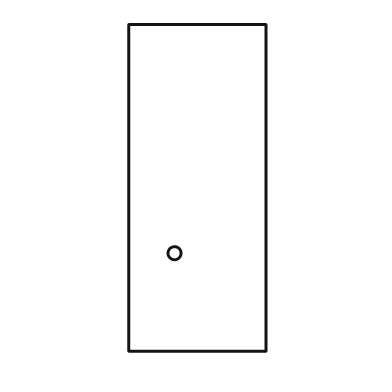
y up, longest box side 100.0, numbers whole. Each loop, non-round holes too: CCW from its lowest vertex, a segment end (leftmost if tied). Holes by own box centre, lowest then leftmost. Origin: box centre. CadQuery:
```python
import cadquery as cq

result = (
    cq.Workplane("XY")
    .moveTo(-21.0, -50.0)
    .lineTo(21.0, -50.0)
    .lineTo(21.0, 50.0)
    .lineTo(-21.0, 50.0)
    .close()
    .moveTo(-7.0, -20.0)
    .circle(2.0)
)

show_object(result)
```